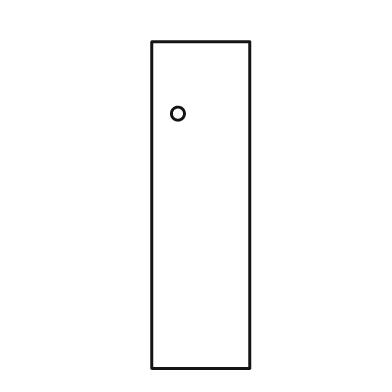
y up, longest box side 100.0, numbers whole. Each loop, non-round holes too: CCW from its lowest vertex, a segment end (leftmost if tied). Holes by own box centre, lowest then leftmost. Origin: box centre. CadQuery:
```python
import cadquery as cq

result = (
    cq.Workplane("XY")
    .moveTo(-15.0, -50.0)
    .lineTo(15.0, -50.0)
    .lineTo(15.0, 50.0)
    .lineTo(-15.0, 50.0)
    .close()
    .moveTo(-7.0, 28.0)
    .circle(2.0)
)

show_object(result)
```